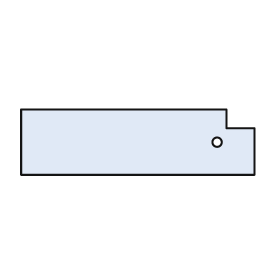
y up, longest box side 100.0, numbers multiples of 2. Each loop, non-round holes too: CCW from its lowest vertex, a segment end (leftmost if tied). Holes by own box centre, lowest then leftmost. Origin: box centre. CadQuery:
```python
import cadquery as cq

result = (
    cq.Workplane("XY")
    .moveTo(-50.0, -14.0)
    .lineTo(50.0, -14.0)
    .lineTo(50.0, 6.0)
    .lineTo(38.0, 6.0)
    .lineTo(38.0, 14.0)
    .lineTo(-50.0, 14.0)
    .close()
    .moveTo(34.0, 0.0)
    .circle(2.0)
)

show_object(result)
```